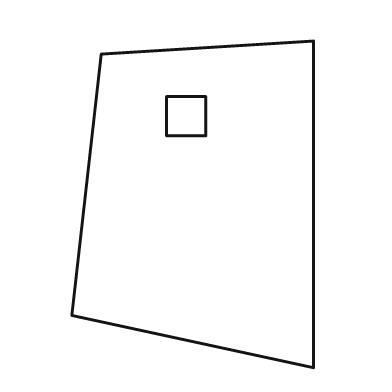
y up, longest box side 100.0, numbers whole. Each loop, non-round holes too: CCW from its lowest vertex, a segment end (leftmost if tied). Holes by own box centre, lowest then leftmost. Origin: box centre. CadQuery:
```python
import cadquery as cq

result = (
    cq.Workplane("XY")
    .moveTo(37.0, -50.0)
    .lineTo(37.0, 50.0)
    .lineTo(-28.0, 46.0)
    .lineTo(-37.0, -34.0)
    .close()
    .moveTo(-8.0, 21.0)
    .lineTo(4.0, 21.0)
    .lineTo(4.0, 33.0)
    .lineTo(-8.0, 33.0)
    .close()
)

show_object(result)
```